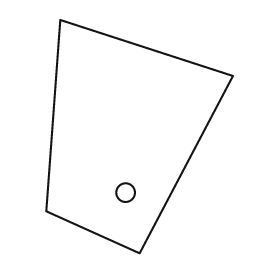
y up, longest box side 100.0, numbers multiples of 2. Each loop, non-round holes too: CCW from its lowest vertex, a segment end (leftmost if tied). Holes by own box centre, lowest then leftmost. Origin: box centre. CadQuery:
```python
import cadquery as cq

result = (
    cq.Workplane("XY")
    .moveTo(0.0, -50.0)
    .lineTo(40.0, 26.0)
    .lineTo(-34.0, 50.0)
    .lineTo(-40.0, -32.0)
    .close()
    .moveTo(-6.0, -24.0)
    .circle(4.0)
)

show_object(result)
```